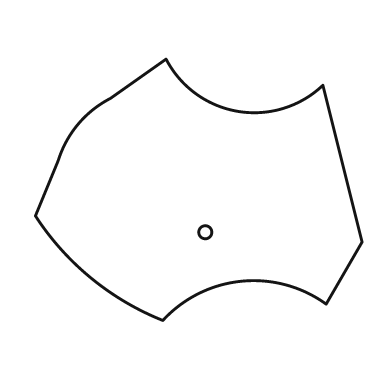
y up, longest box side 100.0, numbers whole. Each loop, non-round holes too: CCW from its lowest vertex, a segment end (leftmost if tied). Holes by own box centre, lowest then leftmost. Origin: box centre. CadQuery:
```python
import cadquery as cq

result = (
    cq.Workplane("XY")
    .moveTo(-11.0, -40.0)
    .threePointArc((13.0, -28.0), (39.0, -35.0))
    .lineTo(50.0, -16.0)
    .lineTo(38.0, 32.0)
    .threePointArc((12.0, 24.0), (-10.0, 40.0))
    .lineTo(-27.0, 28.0)
    .threePointArc((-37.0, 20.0), (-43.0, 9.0))
    .lineTo(-50.0, -8.0)
    .threePointArc((-33.0, -27.0), (-11.0, -40.0))
    .close()
    .moveTo(2.0, -13.0)
    .circle(2.0)
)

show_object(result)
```